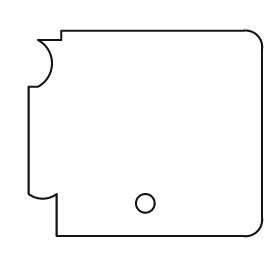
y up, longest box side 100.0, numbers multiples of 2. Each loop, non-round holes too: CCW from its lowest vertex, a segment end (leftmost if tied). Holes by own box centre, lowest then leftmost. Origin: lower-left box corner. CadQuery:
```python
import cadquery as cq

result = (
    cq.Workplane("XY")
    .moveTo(12.0, 0.0)
    .lineTo(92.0, 0.0)
    .threePointArc((98.0, 2.0), (100.0, 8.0))
    .lineTo(100.0, 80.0)
    .threePointArc((98.0, 86.0), (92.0, 88.0))
    .lineTo(14.0, 88.0)
    .lineTo(14.0, 84.0)
    .lineTo(4.0, 84.0)
    .threePointArc((10.0, 74.0), (4.0, 64.0))
    .lineTo(0.0, 64.0)
    .lineTo(0.0, 18.0)
    .threePointArc((6.0, 16.0), (12.0, 18.0))
    .close()
    .moveTo(50.0, 14.0)
    .circle(4.0)
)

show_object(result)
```